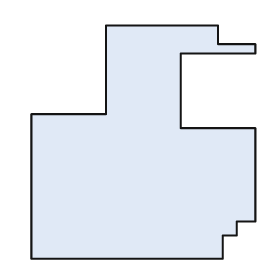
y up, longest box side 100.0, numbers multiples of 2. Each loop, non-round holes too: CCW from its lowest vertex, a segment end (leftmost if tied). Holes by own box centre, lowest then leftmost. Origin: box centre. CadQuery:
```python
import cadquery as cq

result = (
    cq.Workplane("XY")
    .moveTo(-48.0, -50.0)
    .lineTo(34.0, -50.0)
    .lineTo(34.0, -40.0)
    .lineTo(40.0, -40.0)
    .lineTo(40.0, -34.0)
    .lineTo(48.0, -34.0)
    .lineTo(48.0, 6.0)
    .lineTo(16.0, 6.0)
    .lineTo(16.0, 38.0)
    .lineTo(48.0, 38.0)
    .lineTo(48.0, 42.0)
    .lineTo(32.0, 42.0)
    .lineTo(32.0, 50.0)
    .lineTo(-16.0, 50.0)
    .lineTo(-16.0, 12.0)
    .lineTo(-48.0, 12.0)
    .close()
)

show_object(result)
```